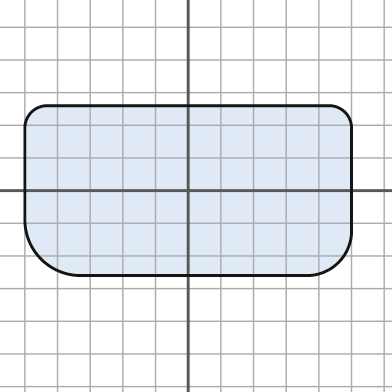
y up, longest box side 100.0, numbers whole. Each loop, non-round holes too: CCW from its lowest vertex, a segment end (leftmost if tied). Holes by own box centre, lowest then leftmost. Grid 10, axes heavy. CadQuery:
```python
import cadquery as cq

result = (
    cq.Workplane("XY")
    .moveTo(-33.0, -26.0)
    .lineTo(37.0, -26.0)
    .threePointArc((46.0, -22.0), (50.0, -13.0))
    .lineTo(50.0, 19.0)
    .threePointArc((48.0, 24.0), (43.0, 26.0))
    .lineTo(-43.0, 26.0)
    .threePointArc((-48.0, 24.0), (-50.0, 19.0))
    .lineTo(-50.0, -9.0)
    .threePointArc((-45.0, -21.0), (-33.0, -26.0))
    .close()
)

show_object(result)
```